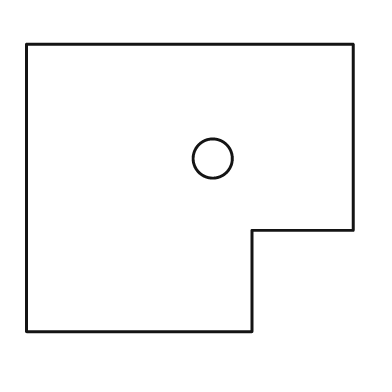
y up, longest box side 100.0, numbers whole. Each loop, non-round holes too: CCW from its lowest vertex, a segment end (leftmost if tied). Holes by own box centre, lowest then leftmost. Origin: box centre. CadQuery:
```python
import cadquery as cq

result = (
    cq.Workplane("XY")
    .moveTo(-50.0, -44.0)
    .lineTo(19.0, -44.0)
    .lineTo(19.0, -13.0)
    .lineTo(50.0, -13.0)
    .lineTo(50.0, 44.0)
    .lineTo(-50.0, 44.0)
    .close()
    .moveTo(7.0, 9.0)
    .circle(6.0)
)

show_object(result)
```